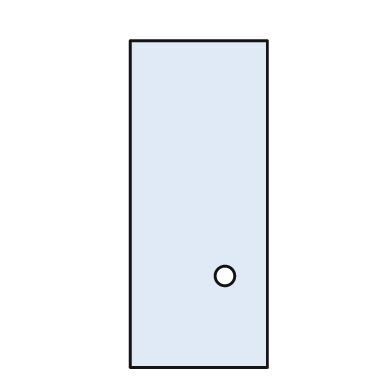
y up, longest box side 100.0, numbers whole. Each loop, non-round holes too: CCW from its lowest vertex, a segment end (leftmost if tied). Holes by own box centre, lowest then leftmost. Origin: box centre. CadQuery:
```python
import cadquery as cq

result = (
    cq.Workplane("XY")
    .moveTo(-21.0, -50.0)
    .lineTo(21.0, -50.0)
    .lineTo(21.0, 50.0)
    .lineTo(-21.0, 50.0)
    .close()
    .moveTo(8.0, -22.0)
    .circle(3.0)
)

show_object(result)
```